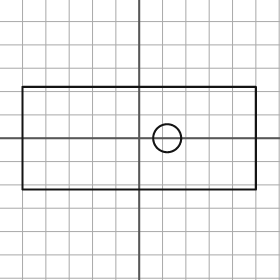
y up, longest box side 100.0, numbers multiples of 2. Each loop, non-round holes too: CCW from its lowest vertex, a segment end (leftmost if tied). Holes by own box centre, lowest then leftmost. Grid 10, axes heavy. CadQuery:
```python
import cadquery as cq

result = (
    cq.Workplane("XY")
    .moveTo(-50.0, -22.0)
    .lineTo(50.0, -22.0)
    .lineTo(50.0, 22.0)
    .lineTo(-50.0, 22.0)
    .close()
    .moveTo(12.0, 0.0)
    .circle(6.0)
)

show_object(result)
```